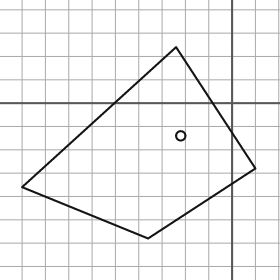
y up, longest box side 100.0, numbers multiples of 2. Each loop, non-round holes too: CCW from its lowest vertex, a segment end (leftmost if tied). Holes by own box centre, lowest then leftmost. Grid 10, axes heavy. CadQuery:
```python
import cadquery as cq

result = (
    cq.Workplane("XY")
    .moveTo(-36.0, -58.0)
    .lineTo(10.0, -28.0)
    .lineTo(-24.0, 24.0)
    .lineTo(-90.0, -36.0)
    .close()
    .moveTo(-22.0, -14.0)
    .circle(2.0)
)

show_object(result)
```